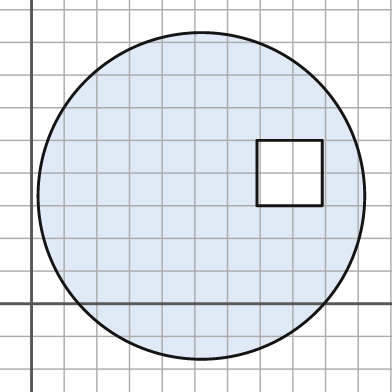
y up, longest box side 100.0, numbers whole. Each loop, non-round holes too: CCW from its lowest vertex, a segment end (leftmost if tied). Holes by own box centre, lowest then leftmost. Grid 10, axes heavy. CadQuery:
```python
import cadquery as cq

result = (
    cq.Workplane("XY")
    .moveTo(52.0, 33.0)
    .circle(50.0)
    .moveTo(69.0, 30.0)
    .lineTo(89.0, 30.0)
    .lineTo(89.0, 50.0)
    .lineTo(69.0, 50.0)
    .close()
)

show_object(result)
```